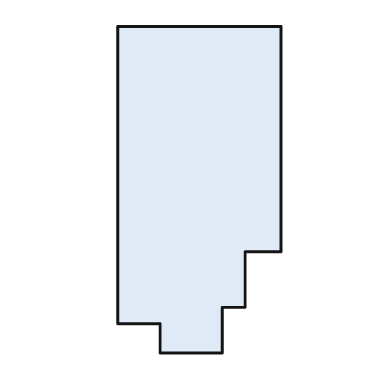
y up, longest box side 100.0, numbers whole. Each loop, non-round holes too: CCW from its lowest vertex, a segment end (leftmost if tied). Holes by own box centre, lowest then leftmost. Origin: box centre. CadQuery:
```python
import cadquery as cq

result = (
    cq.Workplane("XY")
    .moveTo(-12.0, -50.0)
    .lineTo(7.0, -50.0)
    .lineTo(7.0, -36.0)
    .lineTo(14.0, -36.0)
    .lineTo(14.0, -19.0)
    .lineTo(25.0, -19.0)
    .lineTo(25.0, 50.0)
    .lineTo(-25.0, 50.0)
    .lineTo(-25.0, -41.0)
    .lineTo(-12.0, -41.0)
    .close()
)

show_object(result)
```